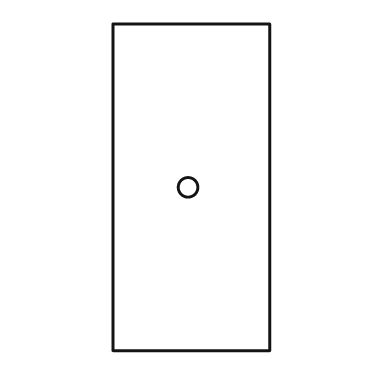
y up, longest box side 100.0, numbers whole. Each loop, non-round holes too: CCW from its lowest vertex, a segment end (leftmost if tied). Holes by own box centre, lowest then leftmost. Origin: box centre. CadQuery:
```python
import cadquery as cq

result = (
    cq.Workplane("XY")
    .moveTo(-24.0, -50.0)
    .lineTo(24.0, -50.0)
    .lineTo(24.0, 50.0)
    .lineTo(-24.0, 50.0)
    .close()
    .moveTo(-1.0, 0.0)
    .circle(3.0)
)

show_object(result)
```